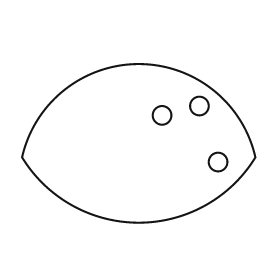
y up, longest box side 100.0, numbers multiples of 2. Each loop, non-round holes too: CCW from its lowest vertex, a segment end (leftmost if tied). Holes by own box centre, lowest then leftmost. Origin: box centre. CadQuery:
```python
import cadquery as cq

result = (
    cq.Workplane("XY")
    .moveTo(-50.0, -6.0)
    .threePointArc((0.0, -34.0), (50.0, -6.0))
    .threePointArc((0.0, 34.0), (-50.0, -6.0))
    .close()
    .moveTo(34.0, -8.0)
    .circle(4.0)
    .moveTo(10.0, 12.0)
    .circle(4.0)
    .moveTo(26.0, 16.0)
    .circle(4.0)
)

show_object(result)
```